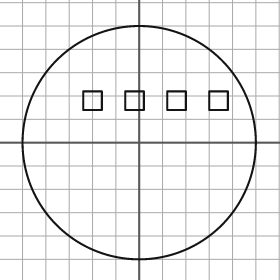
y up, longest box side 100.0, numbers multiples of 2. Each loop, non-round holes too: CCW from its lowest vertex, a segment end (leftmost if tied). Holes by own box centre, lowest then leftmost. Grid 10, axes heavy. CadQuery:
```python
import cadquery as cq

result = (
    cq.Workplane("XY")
    .moveTo(0.0, 0.0)
    .circle(50.0)
    .moveTo(-24.0, 14.0)
    .lineTo(-16.0, 14.0)
    .lineTo(-16.0, 22.0)
    .lineTo(-24.0, 22.0)
    .close()
    .moveTo(-6.0, 14.0)
    .lineTo(2.0, 14.0)
    .lineTo(2.0, 22.0)
    .lineTo(-6.0, 22.0)
    .close()
    .moveTo(12.0, 14.0)
    .lineTo(20.0, 14.0)
    .lineTo(20.0, 22.0)
    .lineTo(12.0, 22.0)
    .close()
    .moveTo(30.0, 14.0)
    .lineTo(38.0, 14.0)
    .lineTo(38.0, 22.0)
    .lineTo(30.0, 22.0)
    .close()
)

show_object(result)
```